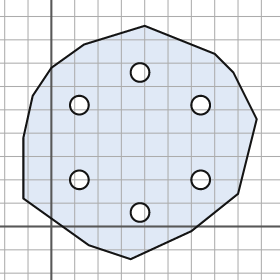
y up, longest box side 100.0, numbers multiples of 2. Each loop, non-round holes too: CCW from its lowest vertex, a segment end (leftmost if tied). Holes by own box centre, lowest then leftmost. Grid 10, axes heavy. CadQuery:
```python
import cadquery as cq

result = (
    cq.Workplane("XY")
    .moveTo(34.0, -14.0)
    .lineTo(60.0, -2.0)
    .lineTo(80.0, 14.0)
    .lineTo(88.0, 46.0)
    .lineTo(78.0, 66.0)
    .lineTo(70.0, 74.0)
    .lineTo(40.0, 86.0)
    .lineTo(14.0, 78.0)
    .lineTo(0.0, 68.0)
    .lineTo(-8.0, 56.0)
    .lineTo(-12.0, 38.0)
    .lineTo(-12.0, 12.0)
    .lineTo(16.0, -8.0)
    .close()
    .moveTo(38.0, 6.0)
    .circle(4.0)
    .moveTo(12.0, 20.0)
    .circle(4.0)
    .moveTo(64.0, 20.0)
    .circle(4.0)
    .moveTo(12.0, 52.0)
    .circle(4.0)
    .moveTo(64.0, 52.0)
    .circle(4.0)
    .moveTo(38.0, 66.0)
    .circle(4.0)
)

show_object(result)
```